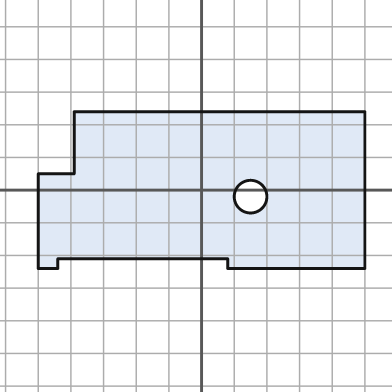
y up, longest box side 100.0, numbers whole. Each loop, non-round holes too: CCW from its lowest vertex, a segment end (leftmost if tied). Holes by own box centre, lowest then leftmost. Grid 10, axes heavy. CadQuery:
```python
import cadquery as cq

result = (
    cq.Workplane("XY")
    .moveTo(-50.0, -24.0)
    .lineTo(-44.0, -24.0)
    .lineTo(-44.0, -21.0)
    .lineTo(8.0, -21.0)
    .lineTo(8.0, -24.0)
    .lineTo(50.0, -24.0)
    .lineTo(50.0, 24.0)
    .lineTo(-39.0, 24.0)
    .lineTo(-39.0, 5.0)
    .lineTo(-50.0, 5.0)
    .close()
    .moveTo(15.0, -2.0)
    .circle(5.0)
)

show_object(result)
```